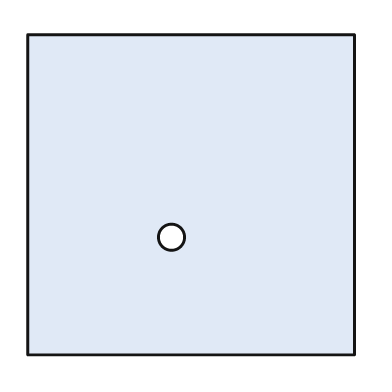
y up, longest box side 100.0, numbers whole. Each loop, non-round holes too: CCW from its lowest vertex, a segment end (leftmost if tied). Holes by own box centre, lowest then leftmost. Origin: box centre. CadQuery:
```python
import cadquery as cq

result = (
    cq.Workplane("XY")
    .moveTo(-50.0, -49.0)
    .lineTo(50.0, -49.0)
    .lineTo(50.0, 49.0)
    .lineTo(-50.0, 49.0)
    .close()
    .moveTo(-6.0, -13.0)
    .circle(4.0)
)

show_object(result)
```